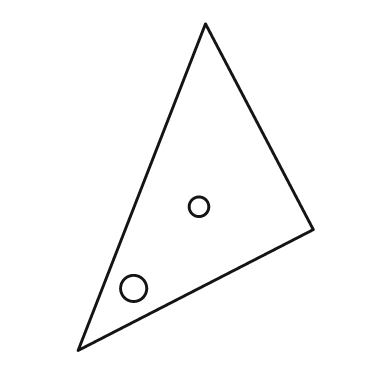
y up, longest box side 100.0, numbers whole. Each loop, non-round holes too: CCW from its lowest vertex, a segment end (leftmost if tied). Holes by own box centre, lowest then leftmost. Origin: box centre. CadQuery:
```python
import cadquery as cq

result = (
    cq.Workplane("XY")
    .moveTo(-36.0, -50.0)
    .lineTo(36.0, -13.0)
    .lineTo(3.0, 50.0)
    .close()
    .moveTo(-19.0, -31.0)
    .circle(4.0)
    .moveTo(1.0, -6.0)
    .circle(3.0)
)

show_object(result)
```